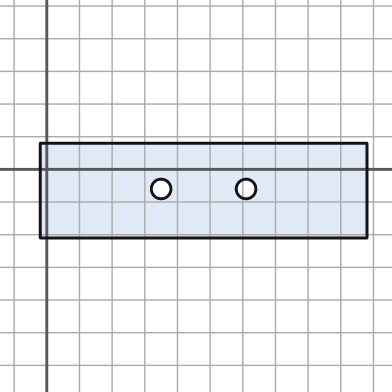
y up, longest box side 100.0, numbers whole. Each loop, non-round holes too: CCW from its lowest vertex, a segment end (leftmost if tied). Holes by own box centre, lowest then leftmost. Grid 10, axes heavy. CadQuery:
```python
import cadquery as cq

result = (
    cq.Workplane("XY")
    .moveTo(-2.0, -21.0)
    .lineTo(98.0, -21.0)
    .lineTo(98.0, 8.0)
    .lineTo(-2.0, 8.0)
    .close()
    .moveTo(35.0, -6.0)
    .circle(3.0)
    .moveTo(61.0, -6.0)
    .circle(3.0)
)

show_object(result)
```